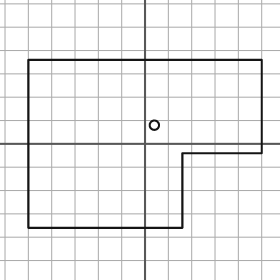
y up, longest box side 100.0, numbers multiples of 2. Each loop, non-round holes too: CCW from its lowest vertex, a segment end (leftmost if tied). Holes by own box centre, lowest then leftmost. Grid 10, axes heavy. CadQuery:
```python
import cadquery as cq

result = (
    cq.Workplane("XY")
    .moveTo(-50.0, -36.0)
    .lineTo(16.0, -36.0)
    .lineTo(16.0, -4.0)
    .lineTo(50.0, -4.0)
    .lineTo(50.0, 36.0)
    .lineTo(-50.0, 36.0)
    .close()
    .moveTo(4.0, 8.0)
    .circle(2.0)
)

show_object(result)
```